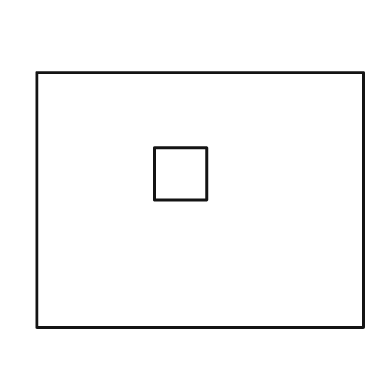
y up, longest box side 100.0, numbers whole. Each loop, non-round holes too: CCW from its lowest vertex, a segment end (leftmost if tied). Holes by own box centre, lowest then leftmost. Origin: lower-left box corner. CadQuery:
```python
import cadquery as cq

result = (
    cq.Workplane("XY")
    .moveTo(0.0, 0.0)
    .lineTo(100.0, 0.0)
    .lineTo(100.0, 78.0)
    .lineTo(0.0, 78.0)
    .close()
    .moveTo(36.0, 39.0)
    .lineTo(52.0, 39.0)
    .lineTo(52.0, 55.0)
    .lineTo(36.0, 55.0)
    .close()
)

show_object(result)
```